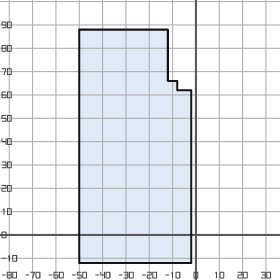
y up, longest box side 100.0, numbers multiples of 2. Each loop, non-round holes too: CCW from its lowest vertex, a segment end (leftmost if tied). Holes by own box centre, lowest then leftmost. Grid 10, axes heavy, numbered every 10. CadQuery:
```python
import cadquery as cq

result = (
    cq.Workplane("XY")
    .moveTo(-50.0, -12.0)
    .lineTo(-2.0, -12.0)
    .lineTo(-2.0, 62.0)
    .lineTo(-8.0, 62.0)
    .lineTo(-8.0, 66.0)
    .lineTo(-12.0, 66.0)
    .lineTo(-12.0, 88.0)
    .lineTo(-50.0, 88.0)
    .close()
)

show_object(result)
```